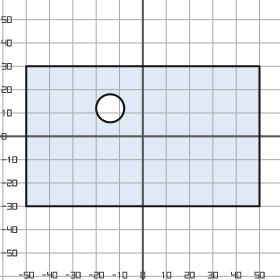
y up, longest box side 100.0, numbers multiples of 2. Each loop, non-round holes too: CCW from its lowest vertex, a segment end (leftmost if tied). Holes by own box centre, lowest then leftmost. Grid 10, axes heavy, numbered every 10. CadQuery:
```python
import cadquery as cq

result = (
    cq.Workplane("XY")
    .moveTo(-50.0, -30.0)
    .lineTo(50.0, -30.0)
    .lineTo(50.0, 30.0)
    .lineTo(-50.0, 30.0)
    .close()
    .moveTo(-14.0, 12.0)
    .circle(6.0)
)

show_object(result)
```